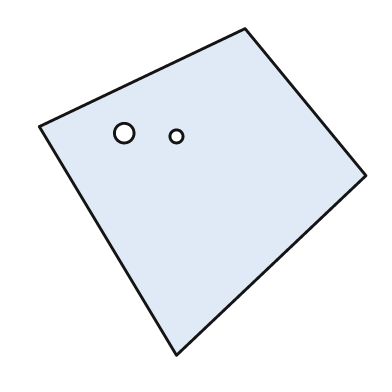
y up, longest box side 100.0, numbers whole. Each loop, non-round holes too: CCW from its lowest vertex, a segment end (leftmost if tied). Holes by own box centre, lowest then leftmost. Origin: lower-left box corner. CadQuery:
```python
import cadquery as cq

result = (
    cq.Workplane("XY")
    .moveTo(42.0, 0.0)
    .lineTo(100.0, 55.0)
    .lineTo(63.0, 100.0)
    .lineTo(0.0, 70.0)
    .close()
    .moveTo(42.0, 67.0)
    .circle(2.0)
    .moveTo(26.0, 68.0)
    .circle(3.0)
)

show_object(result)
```